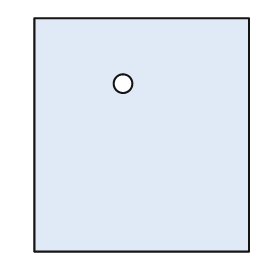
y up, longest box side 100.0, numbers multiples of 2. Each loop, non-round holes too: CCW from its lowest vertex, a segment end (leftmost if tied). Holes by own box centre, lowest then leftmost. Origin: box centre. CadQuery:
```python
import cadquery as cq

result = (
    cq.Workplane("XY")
    .moveTo(-46.0, -50.0)
    .lineTo(46.0, -50.0)
    .lineTo(46.0, 50.0)
    .lineTo(-46.0, 50.0)
    .close()
    .moveTo(-8.0, 22.0)
    .circle(4.0)
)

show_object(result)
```